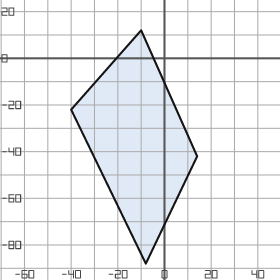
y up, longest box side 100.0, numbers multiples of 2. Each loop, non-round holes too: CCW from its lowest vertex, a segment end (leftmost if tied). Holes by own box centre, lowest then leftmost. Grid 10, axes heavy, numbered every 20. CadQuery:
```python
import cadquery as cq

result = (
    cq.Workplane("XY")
    .moveTo(-8.0, -88.0)
    .lineTo(14.0, -42.0)
    .lineTo(-10.0, 12.0)
    .lineTo(-40.0, -22.0)
    .close()
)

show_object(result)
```